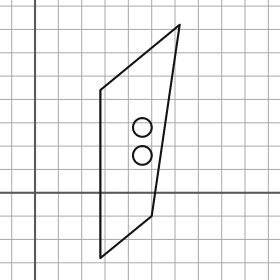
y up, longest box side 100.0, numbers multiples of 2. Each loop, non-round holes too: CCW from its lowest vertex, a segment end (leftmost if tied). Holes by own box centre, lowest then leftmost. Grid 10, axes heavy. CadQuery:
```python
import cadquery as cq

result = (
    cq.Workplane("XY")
    .moveTo(28.0, -28.0)
    .lineTo(50.0, -10.0)
    .lineTo(62.0, 72.0)
    .lineTo(28.0, 44.0)
    .close()
    .moveTo(46.0, 16.0)
    .circle(4.0)
    .moveTo(46.0, 28.0)
    .circle(4.0)
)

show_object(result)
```